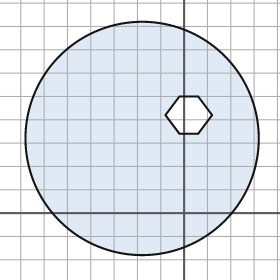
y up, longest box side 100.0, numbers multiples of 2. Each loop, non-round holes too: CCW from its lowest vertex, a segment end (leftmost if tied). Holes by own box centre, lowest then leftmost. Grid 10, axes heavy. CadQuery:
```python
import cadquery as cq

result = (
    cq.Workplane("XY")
    .moveTo(-18.0, 32.0)
    .circle(50.0)
    .moveTo(-2.0, 34.0)
    .lineTo(6.0, 34.0)
    .lineTo(12.0, 42.0)
    .lineTo(6.0, 50.0)
    .lineTo(-2.0, 50.0)
    .lineTo(-8.0, 42.0)
    .close()
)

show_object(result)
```